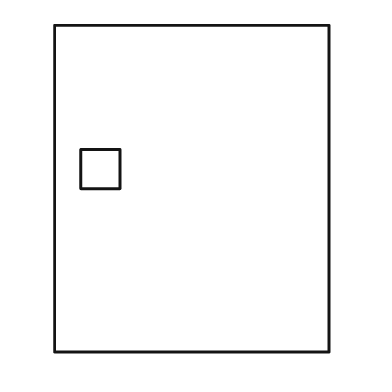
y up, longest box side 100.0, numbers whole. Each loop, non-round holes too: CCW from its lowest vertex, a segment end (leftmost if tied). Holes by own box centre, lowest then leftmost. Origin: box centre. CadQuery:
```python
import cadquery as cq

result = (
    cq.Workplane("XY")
    .moveTo(-42.0, -50.0)
    .lineTo(42.0, -50.0)
    .lineTo(42.0, 50.0)
    .lineTo(-42.0, 50.0)
    .close()
    .moveTo(-34.0, 0.0)
    .lineTo(-22.0, 0.0)
    .lineTo(-22.0, 12.0)
    .lineTo(-34.0, 12.0)
    .close()
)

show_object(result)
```